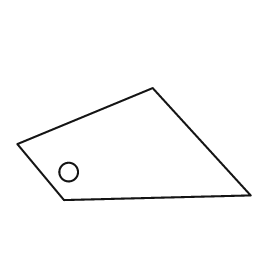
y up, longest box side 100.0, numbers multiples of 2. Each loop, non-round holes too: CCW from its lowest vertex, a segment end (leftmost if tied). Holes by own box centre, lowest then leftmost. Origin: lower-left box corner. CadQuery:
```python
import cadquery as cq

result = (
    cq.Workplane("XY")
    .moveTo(20.0, 0.0)
    .lineTo(100.0, 2.0)
    .lineTo(58.0, 48.0)
    .lineTo(0.0, 24.0)
    .close()
    .moveTo(22.0, 12.0)
    .circle(4.0)
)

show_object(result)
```